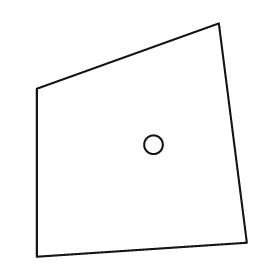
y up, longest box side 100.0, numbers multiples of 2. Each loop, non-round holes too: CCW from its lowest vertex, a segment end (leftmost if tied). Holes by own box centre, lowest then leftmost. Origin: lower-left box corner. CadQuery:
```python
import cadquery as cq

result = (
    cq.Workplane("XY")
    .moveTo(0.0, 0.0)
    .lineTo(90.0, 6.0)
    .lineTo(78.0, 100.0)
    .lineTo(0.0, 72.0)
    .close()
    .moveTo(50.0, 48.0)
    .circle(4.0)
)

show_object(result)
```